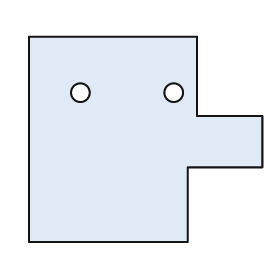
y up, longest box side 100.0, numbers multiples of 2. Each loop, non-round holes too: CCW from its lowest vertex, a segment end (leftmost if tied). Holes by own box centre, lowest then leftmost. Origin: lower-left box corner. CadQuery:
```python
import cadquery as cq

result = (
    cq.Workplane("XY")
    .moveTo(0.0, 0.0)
    .lineTo(68.0, 0.0)
    .lineTo(68.0, 32.0)
    .lineTo(100.0, 32.0)
    .lineTo(100.0, 54.0)
    .lineTo(72.0, 54.0)
    .lineTo(72.0, 88.0)
    .lineTo(0.0, 88.0)
    .close()
    .moveTo(22.0, 64.0)
    .circle(4.0)
    .moveTo(62.0, 64.0)
    .circle(4.0)
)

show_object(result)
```